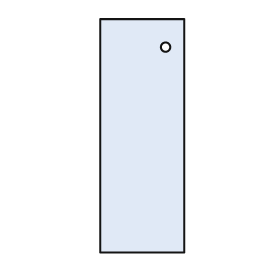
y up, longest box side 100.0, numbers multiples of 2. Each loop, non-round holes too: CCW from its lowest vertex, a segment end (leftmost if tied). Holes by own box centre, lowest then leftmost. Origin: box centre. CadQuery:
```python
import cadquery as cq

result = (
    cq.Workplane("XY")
    .moveTo(-18.0, -50.0)
    .lineTo(18.0, -50.0)
    .lineTo(18.0, 50.0)
    .lineTo(-18.0, 50.0)
    .close()
    .moveTo(10.0, 38.0)
    .circle(2.0)
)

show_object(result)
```